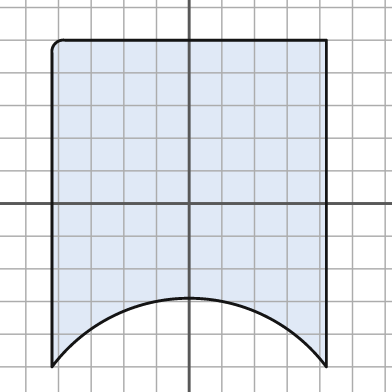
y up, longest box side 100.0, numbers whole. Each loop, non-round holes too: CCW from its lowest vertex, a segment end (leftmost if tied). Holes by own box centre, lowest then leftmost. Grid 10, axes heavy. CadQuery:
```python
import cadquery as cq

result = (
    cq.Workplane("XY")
    .moveTo(-42.0, -50.0)
    .threePointArc((0.0, -29.0), (42.0, -50.0))
    .lineTo(42.0, 50.0)
    .lineTo(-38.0, 50.0)
    .threePointArc((-41.0, 49.0), (-42.0, 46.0))
    .close()
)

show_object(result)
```